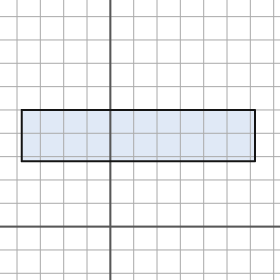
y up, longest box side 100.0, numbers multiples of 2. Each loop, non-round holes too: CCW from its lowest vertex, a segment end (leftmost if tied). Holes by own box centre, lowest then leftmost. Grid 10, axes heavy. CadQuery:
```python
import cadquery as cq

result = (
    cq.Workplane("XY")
    .moveTo(-38.0, 28.0)
    .lineTo(62.0, 28.0)
    .lineTo(62.0, 50.0)
    .lineTo(-38.0, 50.0)
    .close()
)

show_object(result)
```